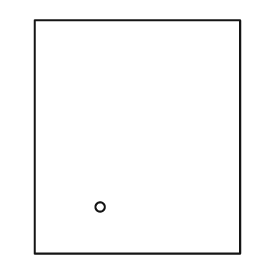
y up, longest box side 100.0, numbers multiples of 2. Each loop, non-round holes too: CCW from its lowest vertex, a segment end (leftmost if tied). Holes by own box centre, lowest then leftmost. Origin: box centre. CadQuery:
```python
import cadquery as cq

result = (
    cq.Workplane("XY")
    .moveTo(-44.0, -50.0)
    .lineTo(44.0, -50.0)
    .lineTo(44.0, 50.0)
    .lineTo(-44.0, 50.0)
    .close()
    .moveTo(-16.0, -30.0)
    .circle(2.0)
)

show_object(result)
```